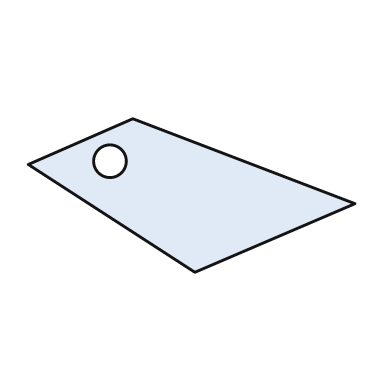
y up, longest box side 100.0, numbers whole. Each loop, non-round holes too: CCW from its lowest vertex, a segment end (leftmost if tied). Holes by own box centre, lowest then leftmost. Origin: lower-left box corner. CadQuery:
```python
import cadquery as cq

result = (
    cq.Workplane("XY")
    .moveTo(51.0, 0.0)
    .lineTo(100.0, 21.0)
    .lineTo(32.0, 47.0)
    .lineTo(0.0, 33.0)
    .close()
    .moveTo(25.0, 34.0)
    .circle(5.0)
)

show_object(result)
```